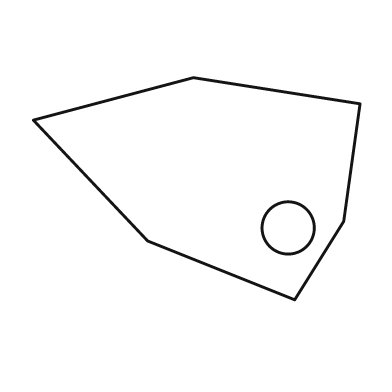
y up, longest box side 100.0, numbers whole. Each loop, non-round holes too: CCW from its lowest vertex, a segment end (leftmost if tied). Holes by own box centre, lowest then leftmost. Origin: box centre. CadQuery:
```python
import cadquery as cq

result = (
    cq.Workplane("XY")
    .moveTo(30.0, -34.0)
    .lineTo(45.0, -10.0)
    .lineTo(50.0, 26.0)
    .lineTo(-1.0, 34.0)
    .lineTo(-50.0, 21.0)
    .lineTo(-15.0, -16.0)
    .close()
    .moveTo(28.0, -12.0)
    .circle(8.0)
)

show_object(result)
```